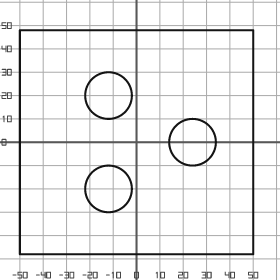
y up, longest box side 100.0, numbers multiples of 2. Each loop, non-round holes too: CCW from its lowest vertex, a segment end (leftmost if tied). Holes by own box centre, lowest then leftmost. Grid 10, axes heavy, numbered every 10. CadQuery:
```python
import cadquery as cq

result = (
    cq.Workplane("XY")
    .moveTo(-50.0, -48.0)
    .lineTo(50.0, -48.0)
    .lineTo(50.0, 48.0)
    .lineTo(-50.0, 48.0)
    .close()
    .moveTo(-12.0, -20.0)
    .circle(10.0)
    .moveTo(24.0, 0.0)
    .circle(10.0)
    .moveTo(-12.0, 20.0)
    .circle(10.0)
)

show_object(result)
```